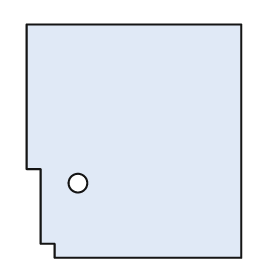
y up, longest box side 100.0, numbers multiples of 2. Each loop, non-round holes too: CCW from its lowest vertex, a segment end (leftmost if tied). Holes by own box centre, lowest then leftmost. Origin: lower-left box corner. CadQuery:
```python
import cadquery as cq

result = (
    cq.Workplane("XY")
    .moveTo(12.0, 0.0)
    .lineTo(92.0, 0.0)
    .lineTo(92.0, 100.0)
    .lineTo(0.0, 100.0)
    .lineTo(0.0, 38.0)
    .lineTo(6.0, 38.0)
    .lineTo(6.0, 6.0)
    .lineTo(12.0, 6.0)
    .close()
    .moveTo(22.0, 32.0)
    .circle(4.0)
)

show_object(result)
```